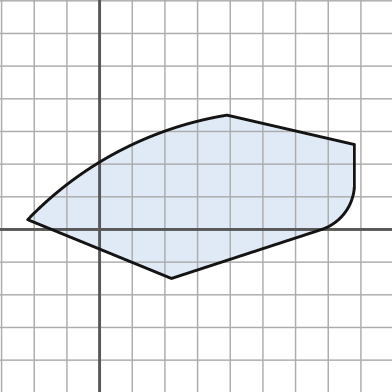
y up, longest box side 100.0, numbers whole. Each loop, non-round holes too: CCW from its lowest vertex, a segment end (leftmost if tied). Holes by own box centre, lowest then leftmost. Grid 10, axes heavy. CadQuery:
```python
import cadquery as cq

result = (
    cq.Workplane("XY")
    .moveTo(22.0, -15.0)
    .lineTo(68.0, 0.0)
    .threePointArc((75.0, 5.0), (78.0, 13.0))
    .lineTo(78.0, 26.0)
    .lineTo(39.0, 35.0)
    .threePointArc((6.0, 24.0), (-22.0, 3.0))
    .close()
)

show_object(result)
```